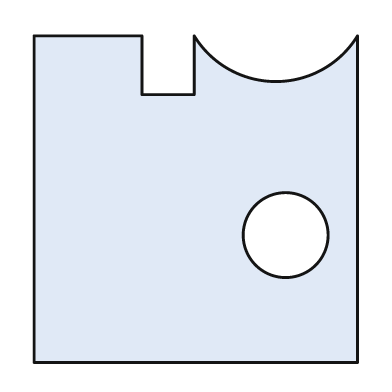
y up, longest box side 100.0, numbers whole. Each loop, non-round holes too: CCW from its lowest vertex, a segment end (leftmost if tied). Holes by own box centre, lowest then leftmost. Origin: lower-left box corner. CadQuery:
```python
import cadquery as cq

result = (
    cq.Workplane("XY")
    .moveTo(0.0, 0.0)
    .lineTo(99.0, 0.0)
    .lineTo(99.0, 100.0)
    .threePointArc((74.0, 86.0), (49.0, 100.0))
    .lineTo(49.0, 82.0)
    .lineTo(33.0, 82.0)
    .lineTo(33.0, 100.0)
    .lineTo(0.0, 100.0)
    .close()
    .moveTo(77.0, 39.0)
    .circle(13.0)
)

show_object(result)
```